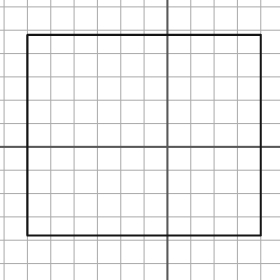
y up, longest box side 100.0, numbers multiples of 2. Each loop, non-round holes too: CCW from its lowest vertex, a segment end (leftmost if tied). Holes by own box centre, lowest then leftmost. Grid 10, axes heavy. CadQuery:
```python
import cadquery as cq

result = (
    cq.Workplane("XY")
    .moveTo(-60.0, -38.0)
    .lineTo(40.0, -38.0)
    .lineTo(40.0, 48.0)
    .lineTo(-60.0, 48.0)
    .close()
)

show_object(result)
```